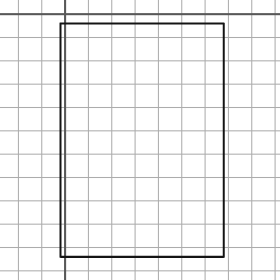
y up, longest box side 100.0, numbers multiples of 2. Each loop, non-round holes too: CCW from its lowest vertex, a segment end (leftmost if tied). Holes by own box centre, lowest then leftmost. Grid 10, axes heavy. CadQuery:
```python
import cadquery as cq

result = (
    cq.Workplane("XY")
    .moveTo(-2.0, -104.0)
    .lineTo(68.0, -104.0)
    .lineTo(68.0, -4.0)
    .lineTo(-2.0, -4.0)
    .close()
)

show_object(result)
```